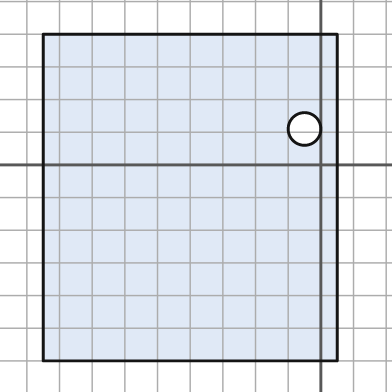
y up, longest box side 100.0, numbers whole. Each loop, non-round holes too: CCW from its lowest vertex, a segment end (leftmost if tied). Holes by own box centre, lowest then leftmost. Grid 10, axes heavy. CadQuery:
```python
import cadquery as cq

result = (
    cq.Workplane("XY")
    .moveTo(-85.0, -60.0)
    .lineTo(5.0, -60.0)
    .lineTo(5.0, 40.0)
    .lineTo(-85.0, 40.0)
    .close()
    .moveTo(-5.0, 11.0)
    .circle(5.0)
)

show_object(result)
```